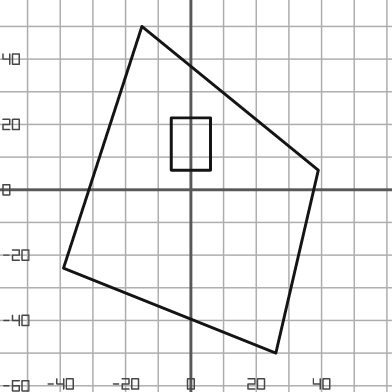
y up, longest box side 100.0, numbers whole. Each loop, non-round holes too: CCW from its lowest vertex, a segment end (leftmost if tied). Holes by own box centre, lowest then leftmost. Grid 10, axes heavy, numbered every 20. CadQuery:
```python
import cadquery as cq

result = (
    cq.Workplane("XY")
    .moveTo(26.0, -50.0)
    .lineTo(39.0, 6.0)
    .lineTo(-15.0, 50.0)
    .lineTo(-39.0, -24.0)
    .close()
    .moveTo(-6.0, 6.0)
    .lineTo(6.0, 6.0)
    .lineTo(6.0, 22.0)
    .lineTo(-6.0, 22.0)
    .close()
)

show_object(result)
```